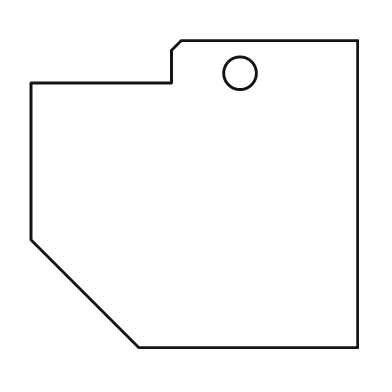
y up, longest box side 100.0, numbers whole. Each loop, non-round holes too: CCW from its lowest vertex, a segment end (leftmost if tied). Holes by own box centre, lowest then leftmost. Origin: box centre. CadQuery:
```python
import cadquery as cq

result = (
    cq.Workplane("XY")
    .moveTo(-17.0, -47.0)
    .lineTo(50.0, -47.0)
    .lineTo(50.0, 47.0)
    .lineTo(-4.0, 47.0)
    .lineTo(-7.0, 44.0)
    .lineTo(-7.0, 34.0)
    .lineTo(-50.0, 34.0)
    .lineTo(-50.0, -14.0)
    .close()
    .moveTo(14.0, 37.0)
    .circle(5.0)
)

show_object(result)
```